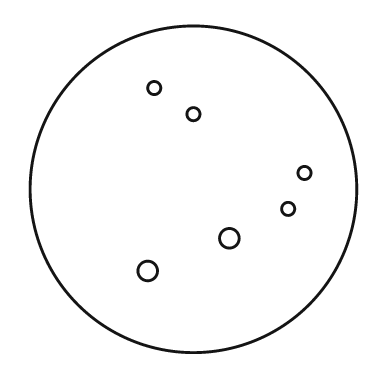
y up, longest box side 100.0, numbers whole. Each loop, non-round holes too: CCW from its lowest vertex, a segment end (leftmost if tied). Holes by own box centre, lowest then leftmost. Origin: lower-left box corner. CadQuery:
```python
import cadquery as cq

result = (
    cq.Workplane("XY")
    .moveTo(50.0, 50.0)
    .circle(50.0)
    .moveTo(36.0, 25.0)
    .circle(3.0)
    .moveTo(61.0, 35.0)
    .circle(3.0)
    .moveTo(79.0, 44.0)
    .circle(2.0)
    .moveTo(84.0, 55.0)
    .circle(2.0)
    .moveTo(50.0, 73.0)
    .circle(2.0)
    .moveTo(38.0, 81.0)
    .circle(2.0)
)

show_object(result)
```